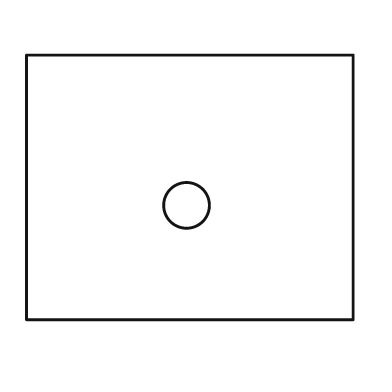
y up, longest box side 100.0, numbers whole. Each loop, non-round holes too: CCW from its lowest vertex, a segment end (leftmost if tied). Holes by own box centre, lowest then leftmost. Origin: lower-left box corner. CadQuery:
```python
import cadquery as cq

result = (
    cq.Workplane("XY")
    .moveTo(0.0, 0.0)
    .lineTo(100.0, 0.0)
    .lineTo(100.0, 81.0)
    .lineTo(0.0, 81.0)
    .close()
    .moveTo(49.0, 35.0)
    .circle(7.0)
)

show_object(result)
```